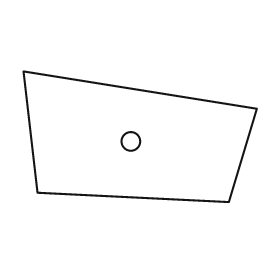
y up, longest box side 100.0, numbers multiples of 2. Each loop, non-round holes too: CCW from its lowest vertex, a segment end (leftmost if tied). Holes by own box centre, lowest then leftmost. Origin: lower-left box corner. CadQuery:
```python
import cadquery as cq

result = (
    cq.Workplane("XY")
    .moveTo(88.0, 0.0)
    .lineTo(100.0, 40.0)
    .lineTo(0.0, 56.0)
    .lineTo(6.0, 4.0)
    .close()
    .moveTo(46.0, 26.0)
    .circle(4.0)
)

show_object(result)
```